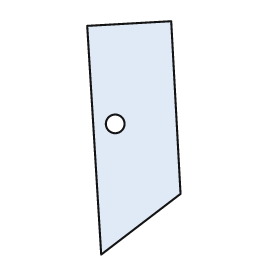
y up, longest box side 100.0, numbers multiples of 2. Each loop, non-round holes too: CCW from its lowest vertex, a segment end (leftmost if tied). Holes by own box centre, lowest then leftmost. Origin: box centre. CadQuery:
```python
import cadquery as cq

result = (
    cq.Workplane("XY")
    .moveTo(-14.0, -50.0)
    .lineTo(20.0, -24.0)
    .lineTo(16.0, 50.0)
    .lineTo(-20.0, 48.0)
    .close()
    .moveTo(-8.0, 6.0)
    .circle(4.0)
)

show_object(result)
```